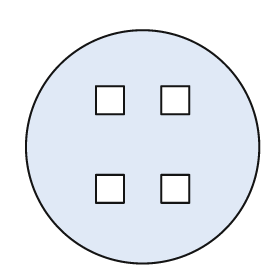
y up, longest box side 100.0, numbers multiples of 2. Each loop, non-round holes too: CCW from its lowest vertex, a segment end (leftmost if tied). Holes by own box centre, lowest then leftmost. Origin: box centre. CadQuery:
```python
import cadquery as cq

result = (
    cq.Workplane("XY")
    .moveTo(0.0, 0.0)
    .circle(50.0)
    .moveTo(-20.0, -24.0)
    .lineTo(-8.0, -24.0)
    .lineTo(-8.0, -12.0)
    .lineTo(-20.0, -12.0)
    .close()
    .moveTo(8.0, -24.0)
    .lineTo(20.0, -24.0)
    .lineTo(20.0, -12.0)
    .lineTo(8.0, -12.0)
    .close()
    .moveTo(-20.0, 14.0)
    .lineTo(-8.0, 14.0)
    .lineTo(-8.0, 26.0)
    .lineTo(-20.0, 26.0)
    .close()
    .moveTo(8.0, 14.0)
    .lineTo(20.0, 14.0)
    .lineTo(20.0, 26.0)
    .lineTo(8.0, 26.0)
    .close()
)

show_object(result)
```